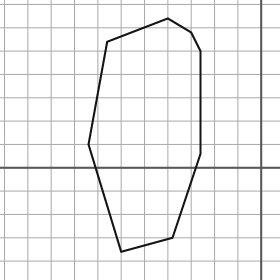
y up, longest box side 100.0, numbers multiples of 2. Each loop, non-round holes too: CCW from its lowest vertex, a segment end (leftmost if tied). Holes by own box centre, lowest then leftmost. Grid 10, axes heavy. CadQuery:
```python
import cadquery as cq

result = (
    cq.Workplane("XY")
    .moveTo(-60.0, -36.0)
    .lineTo(-38.0, -30.0)
    .lineTo(-26.0, 6.0)
    .lineTo(-26.0, 50.0)
    .lineTo(-30.0, 58.0)
    .lineTo(-40.0, 64.0)
    .lineTo(-66.0, 54.0)
    .lineTo(-74.0, 10.0)
    .close()
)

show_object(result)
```